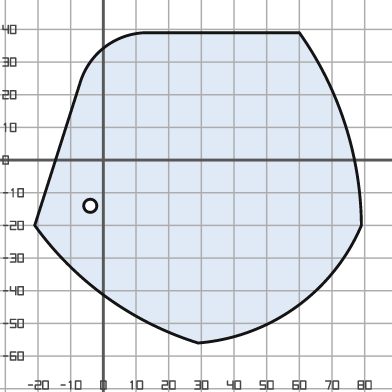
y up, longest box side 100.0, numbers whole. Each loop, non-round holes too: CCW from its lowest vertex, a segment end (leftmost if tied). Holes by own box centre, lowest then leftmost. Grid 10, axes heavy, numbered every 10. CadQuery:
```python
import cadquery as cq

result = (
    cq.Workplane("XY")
    .moveTo(29.0, -56.0)
    .threePointArc((59.0, -45.0), (79.0, -20.0))
    .threePointArc((74.0, 11.0), (60.0, 39.0))
    .lineTo(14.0, 39.0)
    .threePointArc((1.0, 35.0), (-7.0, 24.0))
    .lineTo(-21.0, -20.0)
    .threePointArc((1.0, -42.0), (29.0, -56.0))
    .close()
    .moveTo(-4.0, -14.0)
    .circle(2.0)
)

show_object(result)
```